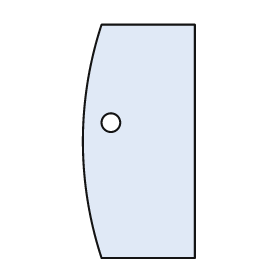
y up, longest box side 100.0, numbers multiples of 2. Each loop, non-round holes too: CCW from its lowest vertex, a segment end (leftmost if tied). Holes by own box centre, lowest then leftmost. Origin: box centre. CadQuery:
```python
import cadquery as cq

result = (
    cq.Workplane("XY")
    .moveTo(-16.0, -50.0)
    .lineTo(24.0, -50.0)
    .lineTo(24.0, 50.0)
    .lineTo(-16.0, 50.0)
    .threePointArc((-24.0, 0.0), (-16.0, -50.0))
    .close()
    .moveTo(-12.0, 8.0)
    .circle(4.0)
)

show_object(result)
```